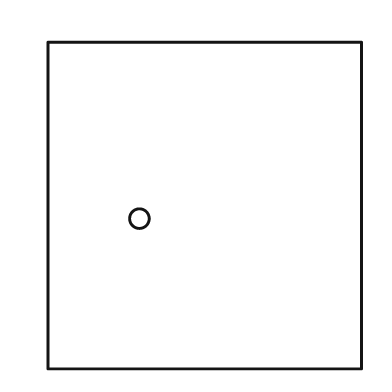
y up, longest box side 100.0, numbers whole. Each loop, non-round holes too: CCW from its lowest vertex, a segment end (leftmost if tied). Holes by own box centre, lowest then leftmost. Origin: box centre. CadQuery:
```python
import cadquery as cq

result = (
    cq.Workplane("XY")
    .moveTo(-48.0, -50.0)
    .lineTo(48.0, -50.0)
    .lineTo(48.0, 50.0)
    .lineTo(-48.0, 50.0)
    .close()
    .moveTo(-20.0, -4.0)
    .circle(3.0)
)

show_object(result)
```